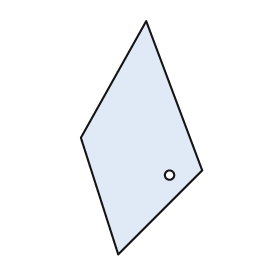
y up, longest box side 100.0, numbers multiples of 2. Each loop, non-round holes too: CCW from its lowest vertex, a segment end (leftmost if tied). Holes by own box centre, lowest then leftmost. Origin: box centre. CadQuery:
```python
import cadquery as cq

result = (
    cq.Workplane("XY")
    .moveTo(-10.0, -50.0)
    .lineTo(26.0, -14.0)
    .lineTo(2.0, 50.0)
    .lineTo(-26.0, 0.0)
    .close()
    .moveTo(12.0, -16.0)
    .circle(2.0)
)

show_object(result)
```